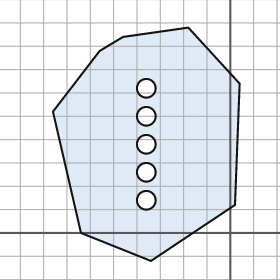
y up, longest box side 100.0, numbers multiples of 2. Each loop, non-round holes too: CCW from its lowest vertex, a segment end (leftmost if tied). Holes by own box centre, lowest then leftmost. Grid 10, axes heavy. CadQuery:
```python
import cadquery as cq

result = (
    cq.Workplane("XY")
    .moveTo(-34.0, -12.0)
    .lineTo(2.0, 12.0)
    .lineTo(4.0, 64.0)
    .lineTo(-18.0, 88.0)
    .lineTo(-46.0, 84.0)
    .lineTo(-56.0, 78.0)
    .lineTo(-76.0, 52.0)
    .lineTo(-64.0, 0.0)
    .close()
    .moveTo(-36.0, 14.0)
    .circle(4.0)
    .moveTo(-36.0, 26.0)
    .circle(4.0)
    .moveTo(-36.0, 38.0)
    .circle(4.0)
    .moveTo(-36.0, 50.0)
    .circle(4.0)
    .moveTo(-36.0, 62.0)
    .circle(4.0)
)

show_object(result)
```